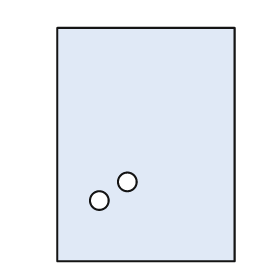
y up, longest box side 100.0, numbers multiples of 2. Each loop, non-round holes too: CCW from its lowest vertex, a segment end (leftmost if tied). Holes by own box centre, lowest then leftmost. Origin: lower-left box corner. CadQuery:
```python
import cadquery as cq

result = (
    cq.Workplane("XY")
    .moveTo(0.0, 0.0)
    .lineTo(76.0, 0.0)
    .lineTo(76.0, 100.0)
    .lineTo(0.0, 100.0)
    .close()
    .moveTo(18.0, 26.0)
    .circle(4.0)
    .moveTo(30.0, 34.0)
    .circle(4.0)
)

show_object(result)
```